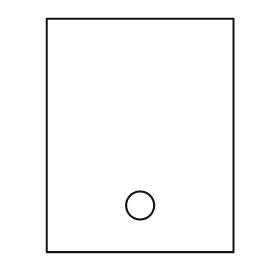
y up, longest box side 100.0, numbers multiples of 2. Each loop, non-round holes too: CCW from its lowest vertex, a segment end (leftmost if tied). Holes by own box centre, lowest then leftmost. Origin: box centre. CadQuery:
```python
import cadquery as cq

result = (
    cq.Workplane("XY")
    .moveTo(-40.0, -50.0)
    .lineTo(40.0, -50.0)
    .lineTo(40.0, 50.0)
    .lineTo(-40.0, 50.0)
    .close()
    .moveTo(0.0, -30.0)
    .circle(6.0)
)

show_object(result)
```